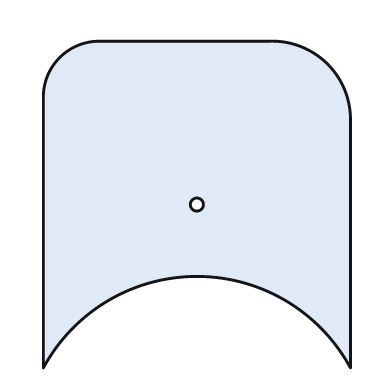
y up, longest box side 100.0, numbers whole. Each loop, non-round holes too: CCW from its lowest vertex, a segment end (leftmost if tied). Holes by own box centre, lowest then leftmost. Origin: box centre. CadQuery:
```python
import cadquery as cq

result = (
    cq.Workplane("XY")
    .moveTo(-47.0, -50.0)
    .threePointArc((0.0, -22.0), (47.0, -50.0))
    .lineTo(47.0, 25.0)
    .threePointArc((40.0, 43.0), (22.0, 50.0))
    .lineTo(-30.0, 50.0)
    .threePointArc((-42.0, 45.0), (-47.0, 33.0))
    .close()
    .moveTo(0.0, 0.0)
    .circle(2.0)
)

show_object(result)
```